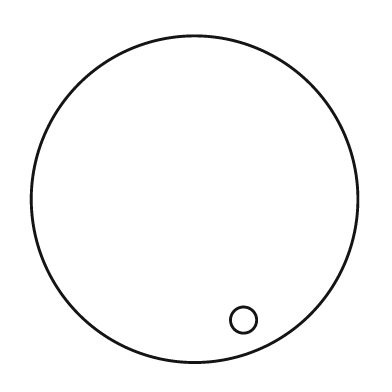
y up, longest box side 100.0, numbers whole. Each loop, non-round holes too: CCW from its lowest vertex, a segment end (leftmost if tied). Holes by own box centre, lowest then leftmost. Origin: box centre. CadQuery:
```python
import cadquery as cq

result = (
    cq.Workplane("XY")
    .moveTo(0.0, 0.0)
    .circle(50.0)
    .moveTo(15.0, -37.0)
    .circle(4.0)
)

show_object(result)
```